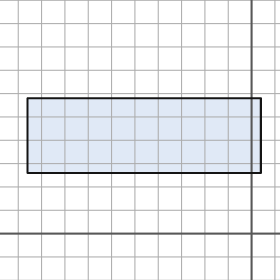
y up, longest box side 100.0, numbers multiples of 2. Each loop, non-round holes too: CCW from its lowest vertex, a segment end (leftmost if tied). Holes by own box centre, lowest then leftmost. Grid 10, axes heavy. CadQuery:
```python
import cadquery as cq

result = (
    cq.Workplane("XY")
    .moveTo(-96.0, 26.0)
    .lineTo(4.0, 26.0)
    .lineTo(4.0, 58.0)
    .lineTo(-96.0, 58.0)
    .close()
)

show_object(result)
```